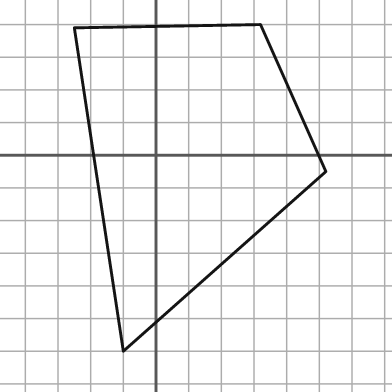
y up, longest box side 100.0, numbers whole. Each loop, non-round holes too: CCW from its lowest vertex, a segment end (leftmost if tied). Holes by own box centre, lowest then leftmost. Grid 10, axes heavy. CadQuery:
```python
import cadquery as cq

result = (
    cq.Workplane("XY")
    .moveTo(-10.0, -60.0)
    .lineTo(52.0, -5.0)
    .lineTo(32.0, 40.0)
    .lineTo(-25.0, 39.0)
    .close()
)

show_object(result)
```